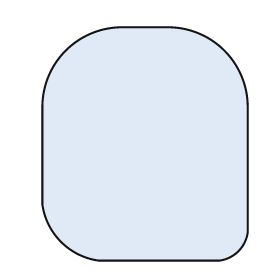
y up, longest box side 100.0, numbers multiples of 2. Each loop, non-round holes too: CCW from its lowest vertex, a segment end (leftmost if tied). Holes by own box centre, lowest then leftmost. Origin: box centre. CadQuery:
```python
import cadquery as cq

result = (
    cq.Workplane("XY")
    .moveTo(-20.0, -50.0)
    .lineTo(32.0, -50.0)
    .threePointArc((40.0, -46.0), (44.0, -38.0))
    .lineTo(44.0, 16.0)
    .threePointArc((34.0, 40.0), (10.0, 50.0))
    .lineTo(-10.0, 50.0)
    .threePointArc((-34.0, 40.0), (-44.0, 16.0))
    .lineTo(-44.0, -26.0)
    .threePointArc((-36.0, -42.0), (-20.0, -50.0))
    .close()
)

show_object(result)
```